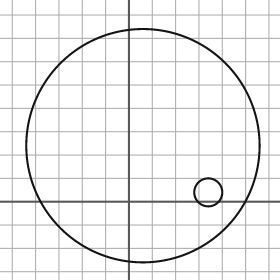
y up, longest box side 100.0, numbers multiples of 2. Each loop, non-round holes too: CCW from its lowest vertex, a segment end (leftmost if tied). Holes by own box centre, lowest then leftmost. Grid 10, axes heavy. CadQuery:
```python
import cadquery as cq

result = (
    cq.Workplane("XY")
    .moveTo(6.0, 24.0)
    .circle(50.0)
    .moveTo(34.0, 4.0)
    .circle(6.0)
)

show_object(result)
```